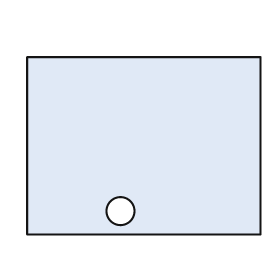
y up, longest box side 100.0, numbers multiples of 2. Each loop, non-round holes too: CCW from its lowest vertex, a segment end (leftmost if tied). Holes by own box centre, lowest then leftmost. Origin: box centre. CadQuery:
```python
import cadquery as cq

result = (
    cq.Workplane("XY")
    .moveTo(-50.0, -38.0)
    .lineTo(50.0, -38.0)
    .lineTo(50.0, 38.0)
    .lineTo(-50.0, 38.0)
    .close()
    .moveTo(-10.0, -28.0)
    .circle(6.0)
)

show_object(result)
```